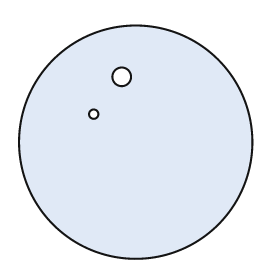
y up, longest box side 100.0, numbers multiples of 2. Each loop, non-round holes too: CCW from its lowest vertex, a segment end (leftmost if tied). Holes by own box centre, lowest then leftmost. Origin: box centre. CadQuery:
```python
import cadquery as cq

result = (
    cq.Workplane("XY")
    .moveTo(0.0, 0.0)
    .circle(50.0)
    .moveTo(-18.0, 12.0)
    .circle(2.0)
    .moveTo(-6.0, 28.0)
    .circle(4.0)
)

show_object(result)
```